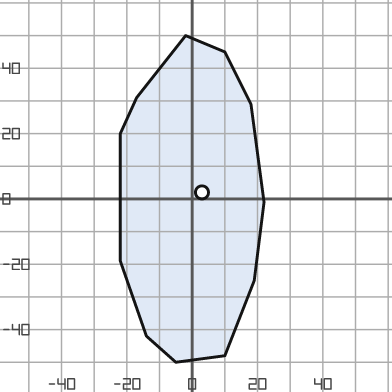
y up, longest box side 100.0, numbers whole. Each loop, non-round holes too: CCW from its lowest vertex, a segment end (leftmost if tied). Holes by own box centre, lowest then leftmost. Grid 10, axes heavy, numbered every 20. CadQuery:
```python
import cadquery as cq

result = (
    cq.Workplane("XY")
    .moveTo(-5.0, -50.0)
    .lineTo(10.0, -48.0)
    .lineTo(19.0, -25.0)
    .lineTo(22.0, -1.0)
    .lineTo(18.0, 29.0)
    .lineTo(10.0, 45.0)
    .lineTo(-2.0, 50.0)
    .lineTo(-17.0, 31.0)
    .lineTo(-22.0, 20.0)
    .lineTo(-22.0, -19.0)
    .lineTo(-14.0, -42.0)
    .close()
    .moveTo(3.0, 2.0)
    .circle(2.0)
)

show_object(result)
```